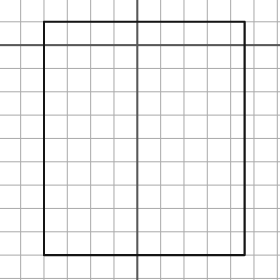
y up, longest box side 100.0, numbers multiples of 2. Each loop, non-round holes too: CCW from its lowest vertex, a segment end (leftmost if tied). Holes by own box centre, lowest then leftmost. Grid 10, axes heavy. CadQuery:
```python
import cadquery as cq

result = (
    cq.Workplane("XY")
    .moveTo(-40.0, -90.0)
    .lineTo(46.0, -90.0)
    .lineTo(46.0, 10.0)
    .lineTo(-40.0, 10.0)
    .close()
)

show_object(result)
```